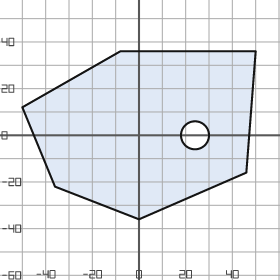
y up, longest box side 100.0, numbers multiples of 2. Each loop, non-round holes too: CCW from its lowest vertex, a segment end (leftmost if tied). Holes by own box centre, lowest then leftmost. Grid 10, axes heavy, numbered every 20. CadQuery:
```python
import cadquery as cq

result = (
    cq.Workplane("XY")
    .moveTo(0.0, -36.0)
    .lineTo(46.0, -16.0)
    .lineTo(50.0, 36.0)
    .lineTo(-8.0, 36.0)
    .lineTo(-50.0, 12.0)
    .lineTo(-36.0, -22.0)
    .close()
    .moveTo(24.0, 0.0)
    .circle(6.0)
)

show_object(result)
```